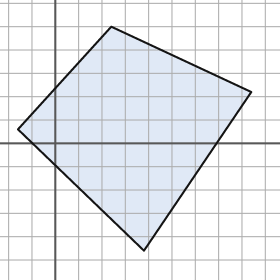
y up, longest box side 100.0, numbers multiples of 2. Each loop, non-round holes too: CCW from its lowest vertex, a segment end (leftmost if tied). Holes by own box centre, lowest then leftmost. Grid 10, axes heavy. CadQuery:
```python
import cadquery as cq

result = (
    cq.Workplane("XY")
    .moveTo(38.0, -46.0)
    .lineTo(84.0, 22.0)
    .lineTo(24.0, 50.0)
    .lineTo(-16.0, 6.0)
    .close()
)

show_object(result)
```